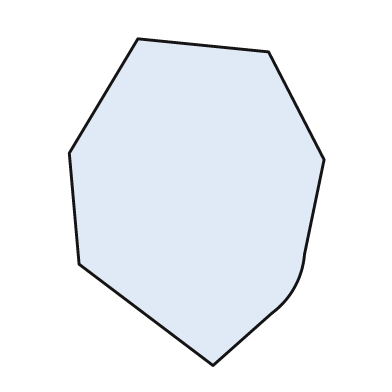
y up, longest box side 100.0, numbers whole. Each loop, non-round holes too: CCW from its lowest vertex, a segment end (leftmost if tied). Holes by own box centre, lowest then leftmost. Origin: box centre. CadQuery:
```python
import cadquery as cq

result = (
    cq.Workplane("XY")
    .moveTo(5.0, -50.0)
    .lineTo(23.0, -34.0)
    .threePointArc((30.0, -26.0), (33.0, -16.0))
    .lineTo(39.0, 13.0)
    .lineTo(22.0, 46.0)
    .lineTo(-18.0, 50.0)
    .lineTo(-39.0, 15.0)
    .lineTo(-36.0, -19.0)
    .close()
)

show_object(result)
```